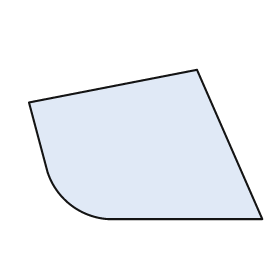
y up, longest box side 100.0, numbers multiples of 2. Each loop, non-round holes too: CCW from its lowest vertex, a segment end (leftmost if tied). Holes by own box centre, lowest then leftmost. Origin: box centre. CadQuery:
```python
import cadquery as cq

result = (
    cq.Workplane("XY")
    .moveTo(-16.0, -32.0)
    .lineTo(50.0, -32.0)
    .lineTo(22.0, 32.0)
    .lineTo(-50.0, 18.0)
    .lineTo(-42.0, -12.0)
    .threePointArc((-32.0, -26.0), (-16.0, -32.0))
    .close()
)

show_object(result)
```